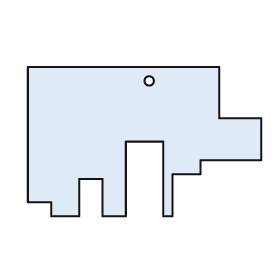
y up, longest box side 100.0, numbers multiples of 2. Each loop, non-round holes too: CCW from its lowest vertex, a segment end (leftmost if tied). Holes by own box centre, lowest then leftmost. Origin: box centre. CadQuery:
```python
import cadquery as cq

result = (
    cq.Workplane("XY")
    .moveTo(-40.0, -32.0)
    .lineTo(-28.0, -32.0)
    .lineTo(-28.0, -16.0)
    .lineTo(-18.0, -16.0)
    .lineTo(-18.0, -32.0)
    .lineTo(-8.0, -32.0)
    .lineTo(-8.0, 0.0)
    .lineTo(8.0, 0.0)
    .lineTo(8.0, -32.0)
    .lineTo(12.0, -32.0)
    .lineTo(12.0, -14.0)
    .lineTo(24.0, -14.0)
    .lineTo(24.0, -8.0)
    .lineTo(50.0, -8.0)
    .lineTo(50.0, 10.0)
    .lineTo(32.0, 10.0)
    .lineTo(32.0, 32.0)
    .lineTo(-50.0, 32.0)
    .lineTo(-50.0, -26.0)
    .lineTo(-40.0, -26.0)
    .close()
    .moveTo(2.0, 26.0)
    .circle(2.0)
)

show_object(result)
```